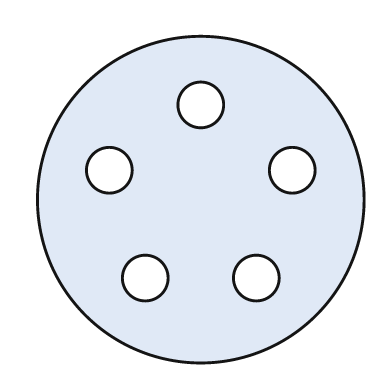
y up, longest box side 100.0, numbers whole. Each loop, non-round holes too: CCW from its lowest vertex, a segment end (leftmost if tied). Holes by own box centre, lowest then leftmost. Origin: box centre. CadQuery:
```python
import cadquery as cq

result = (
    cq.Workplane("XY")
    .moveTo(0.0, 0.0)
    .circle(50.0)
    .moveTo(-17.0, -24.0)
    .circle(7.0)
    .moveTo(17.0, -24.0)
    .circle(7.0)
    .moveTo(-28.0, 9.0)
    .circle(7.0)
    .moveTo(28.0, 9.0)
    .circle(7.0)
    .moveTo(0.0, 29.0)
    .circle(7.0)
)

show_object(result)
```